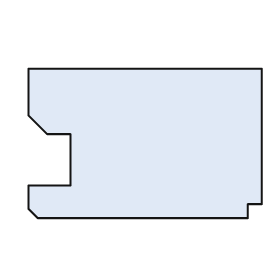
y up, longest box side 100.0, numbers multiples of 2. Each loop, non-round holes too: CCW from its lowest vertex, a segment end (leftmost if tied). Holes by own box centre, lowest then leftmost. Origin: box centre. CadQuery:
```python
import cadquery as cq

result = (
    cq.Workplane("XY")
    .moveTo(-46.0, -32.0)
    .lineTo(44.0, -32.0)
    .lineTo(44.0, -26.0)
    .lineTo(50.0, -26.0)
    .lineTo(50.0, 32.0)
    .lineTo(-50.0, 32.0)
    .lineTo(-50.0, 12.0)
    .lineTo(-42.0, 4.0)
    .lineTo(-32.0, 4.0)
    .lineTo(-32.0, -18.0)
    .lineTo(-50.0, -18.0)
    .lineTo(-50.0, -28.0)
    .close()
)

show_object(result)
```